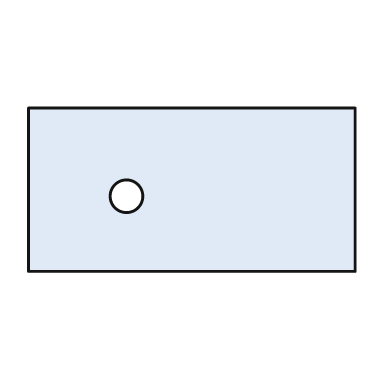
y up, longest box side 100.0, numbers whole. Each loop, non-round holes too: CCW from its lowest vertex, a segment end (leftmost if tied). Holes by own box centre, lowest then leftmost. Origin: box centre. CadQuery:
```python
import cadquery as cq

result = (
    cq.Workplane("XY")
    .moveTo(-50.0, -25.0)
    .lineTo(50.0, -25.0)
    .lineTo(50.0, 25.0)
    .lineTo(-50.0, 25.0)
    .close()
    .moveTo(-20.0, -2.0)
    .circle(5.0)
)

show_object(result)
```